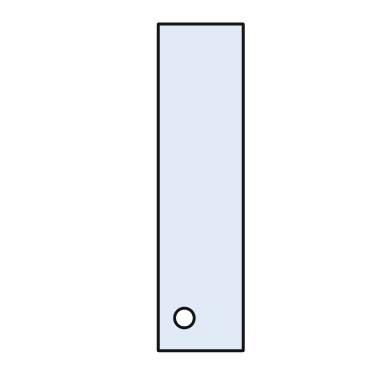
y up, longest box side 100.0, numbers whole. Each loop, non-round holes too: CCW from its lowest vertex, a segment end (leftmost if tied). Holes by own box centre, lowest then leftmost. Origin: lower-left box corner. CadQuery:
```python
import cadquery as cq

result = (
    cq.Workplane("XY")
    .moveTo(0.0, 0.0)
    .lineTo(26.0, 0.0)
    .lineTo(26.0, 100.0)
    .lineTo(0.0, 100.0)
    .close()
    .moveTo(8.0, 10.0)
    .circle(3.0)
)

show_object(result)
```